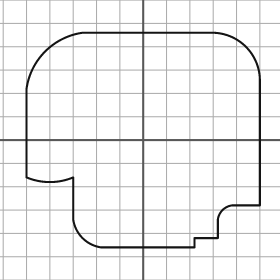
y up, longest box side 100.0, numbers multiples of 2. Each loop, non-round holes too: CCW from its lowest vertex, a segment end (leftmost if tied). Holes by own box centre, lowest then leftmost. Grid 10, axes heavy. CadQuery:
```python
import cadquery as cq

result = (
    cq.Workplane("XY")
    .moveTo(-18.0, -46.0)
    .lineTo(22.0, -46.0)
    .lineTo(22.0, -42.0)
    .lineTo(32.0, -42.0)
    .lineTo(32.0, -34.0)
    .threePointArc((34.0, -30.0), (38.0, -28.0))
    .lineTo(50.0, -28.0)
    .lineTo(50.0, 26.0)
    .threePointArc((44.0, 40.0), (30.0, 46.0))
    .lineTo(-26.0, 46.0)
    .threePointArc((-42.0, 38.0), (-50.0, 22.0))
    .lineTo(-50.0, -16.0)
    .threePointArc((-40.0, -18.0), (-30.0, -16.0))
    .lineTo(-30.0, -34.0)
    .threePointArc((-26.0, -42.0), (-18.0, -46.0))
    .close()
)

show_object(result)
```